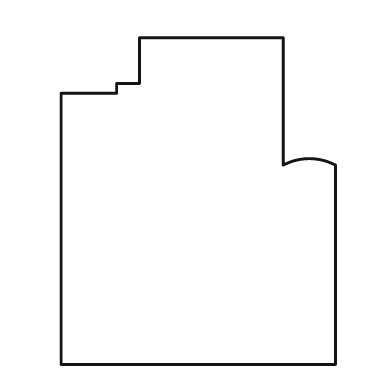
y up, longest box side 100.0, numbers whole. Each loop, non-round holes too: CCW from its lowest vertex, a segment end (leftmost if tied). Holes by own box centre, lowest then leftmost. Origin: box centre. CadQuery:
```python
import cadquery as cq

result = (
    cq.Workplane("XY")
    .moveTo(-42.0, -50.0)
    .lineTo(42.0, -50.0)
    .lineTo(42.0, 11.0)
    .threePointArc((34.0, 13.0), (26.0, 11.0))
    .lineTo(26.0, 50.0)
    .lineTo(-18.0, 50.0)
    .lineTo(-18.0, 36.0)
    .lineTo(-25.0, 36.0)
    .lineTo(-25.0, 33.0)
    .lineTo(-42.0, 33.0)
    .close()
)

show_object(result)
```